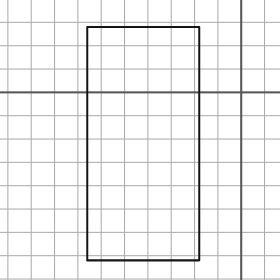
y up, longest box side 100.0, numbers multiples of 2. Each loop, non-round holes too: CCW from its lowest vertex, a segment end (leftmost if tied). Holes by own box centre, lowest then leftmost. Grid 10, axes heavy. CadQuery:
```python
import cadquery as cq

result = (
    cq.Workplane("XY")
    .moveTo(-66.0, -72.0)
    .lineTo(-18.0, -72.0)
    .lineTo(-18.0, 28.0)
    .lineTo(-66.0, 28.0)
    .close()
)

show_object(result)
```